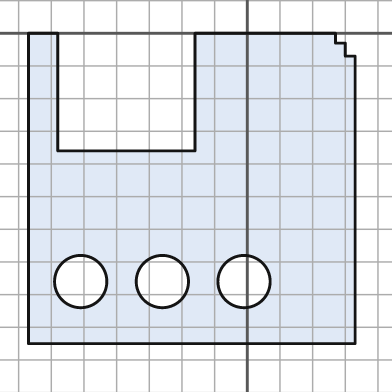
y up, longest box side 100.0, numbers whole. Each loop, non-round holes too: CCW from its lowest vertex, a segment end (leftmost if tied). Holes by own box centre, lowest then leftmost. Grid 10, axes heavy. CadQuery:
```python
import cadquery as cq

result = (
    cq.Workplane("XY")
    .moveTo(-67.0, -95.0)
    .lineTo(33.0, -95.0)
    .lineTo(33.0, -7.0)
    .lineTo(30.0, -7.0)
    .lineTo(30.0, -3.0)
    .lineTo(27.0, -3.0)
    .lineTo(27.0, 0.0)
    .lineTo(-16.0, 0.0)
    .lineTo(-16.0, -36.0)
    .lineTo(-58.0, -36.0)
    .lineTo(-58.0, 0.0)
    .lineTo(-67.0, 0.0)
    .close()
    .moveTo(-51.0, -76.0)
    .circle(8.0)
    .moveTo(-26.0, -76.0)
    .circle(8.0)
    .moveTo(-1.0, -76.0)
    .circle(8.0)
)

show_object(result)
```